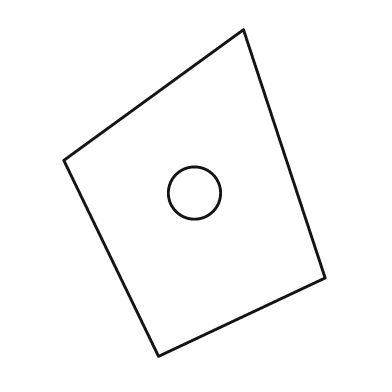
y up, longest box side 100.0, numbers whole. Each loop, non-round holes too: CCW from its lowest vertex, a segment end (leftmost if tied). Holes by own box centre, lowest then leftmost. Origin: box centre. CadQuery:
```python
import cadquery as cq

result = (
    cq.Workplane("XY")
    .moveTo(-11.0, -50.0)
    .lineTo(40.0, -26.0)
    .lineTo(15.0, 50.0)
    .lineTo(-40.0, 10.0)
    .close()
    .moveTo(0.0, 0.0)
    .circle(8.0)
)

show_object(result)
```